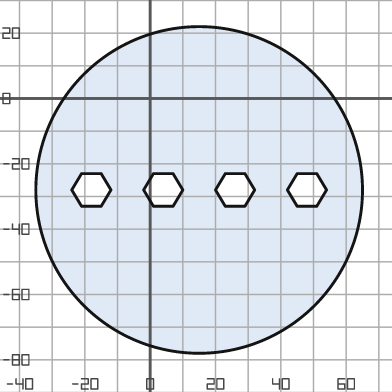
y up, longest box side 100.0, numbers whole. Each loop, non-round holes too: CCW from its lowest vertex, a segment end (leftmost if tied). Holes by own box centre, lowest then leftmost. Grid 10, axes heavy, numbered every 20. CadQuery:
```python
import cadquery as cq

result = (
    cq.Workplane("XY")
    .moveTo(15.0, -28.0)
    .circle(50.0)
    .moveTo(-21.0, -33.0)
    .lineTo(-15.0, -33.0)
    .lineTo(-12.0, -28.0)
    .lineTo(-15.0, -23.0)
    .lineTo(-21.0, -23.0)
    .lineTo(-24.0, -28.0)
    .close()
    .moveTo(1.0, -33.0)
    .lineTo(7.0, -33.0)
    .lineTo(10.0, -28.0)
    .lineTo(7.0, -23.0)
    .lineTo(1.0, -23.0)
    .lineTo(-2.0, -28.0)
    .close()
    .moveTo(23.0, -33.0)
    .lineTo(29.0, -33.0)
    .lineTo(32.0, -28.0)
    .lineTo(29.0, -23.0)
    .lineTo(23.0, -23.0)
    .lineTo(20.0, -28.0)
    .close()
    .moveTo(45.0, -33.0)
    .lineTo(51.0, -33.0)
    .lineTo(54.0, -28.0)
    .lineTo(51.0, -23.0)
    .lineTo(45.0, -23.0)
    .lineTo(42.0, -28.0)
    .close()
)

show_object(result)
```